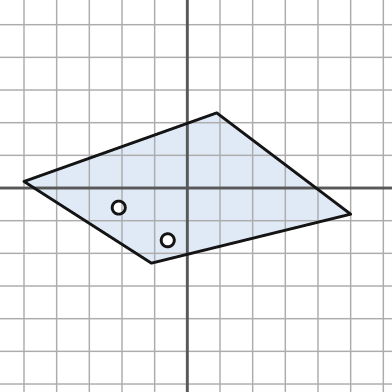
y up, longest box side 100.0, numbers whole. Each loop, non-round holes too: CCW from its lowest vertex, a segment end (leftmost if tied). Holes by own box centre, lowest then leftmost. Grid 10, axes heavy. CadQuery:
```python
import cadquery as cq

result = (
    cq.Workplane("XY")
    .moveTo(-11.0, -23.0)
    .lineTo(50.0, -8.0)
    .lineTo(9.0, 23.0)
    .lineTo(-50.0, 2.0)
    .close()
    .moveTo(-6.0, -16.0)
    .circle(2.0)
    .moveTo(-21.0, -6.0)
    .circle(2.0)
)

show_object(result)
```